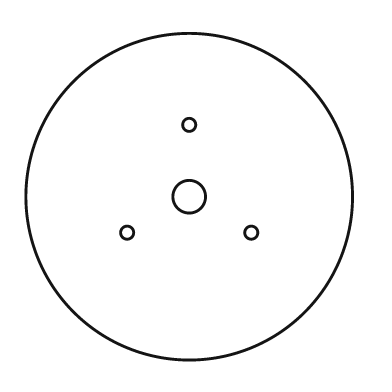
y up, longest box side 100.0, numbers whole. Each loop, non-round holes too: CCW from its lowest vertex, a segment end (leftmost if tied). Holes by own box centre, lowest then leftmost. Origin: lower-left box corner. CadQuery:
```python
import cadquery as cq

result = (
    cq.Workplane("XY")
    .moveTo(50.0, 50.0)
    .circle(50.0)
    .moveTo(31.0, 39.0)
    .circle(2.0)
    .moveTo(69.0, 39.0)
    .circle(2.0)
    .moveTo(50.0, 50.0)
    .circle(5.0)
    .moveTo(50.0, 72.0)
    .circle(2.0)
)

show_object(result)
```